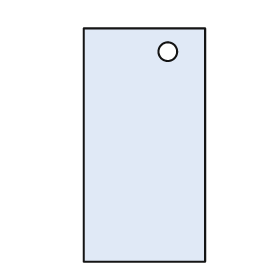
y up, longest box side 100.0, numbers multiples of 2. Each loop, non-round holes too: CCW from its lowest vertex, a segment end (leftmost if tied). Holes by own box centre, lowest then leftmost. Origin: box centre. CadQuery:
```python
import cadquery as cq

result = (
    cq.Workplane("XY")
    .moveTo(-26.0, -50.0)
    .lineTo(26.0, -50.0)
    .lineTo(26.0, 50.0)
    .lineTo(-26.0, 50.0)
    .close()
    .moveTo(10.0, 40.0)
    .circle(4.0)
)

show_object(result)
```